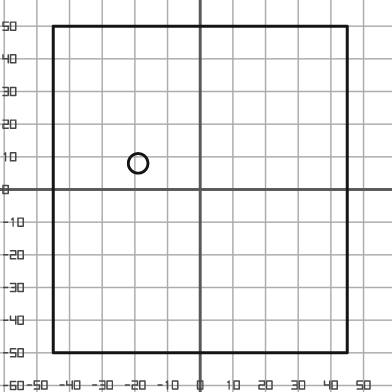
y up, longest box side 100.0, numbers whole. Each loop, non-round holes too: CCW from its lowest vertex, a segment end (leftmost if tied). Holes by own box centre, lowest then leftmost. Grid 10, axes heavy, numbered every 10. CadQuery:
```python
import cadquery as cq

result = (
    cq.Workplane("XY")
    .moveTo(-45.0, -50.0)
    .lineTo(45.0, -50.0)
    .lineTo(45.0, 50.0)
    .lineTo(-45.0, 50.0)
    .close()
    .moveTo(-19.0, 8.0)
    .circle(3.0)
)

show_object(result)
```